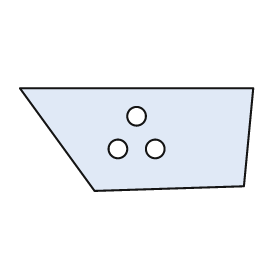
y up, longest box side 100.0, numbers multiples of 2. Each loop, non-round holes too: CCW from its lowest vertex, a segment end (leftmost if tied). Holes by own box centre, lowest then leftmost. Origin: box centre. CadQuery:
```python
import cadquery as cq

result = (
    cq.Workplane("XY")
    .moveTo(-18.0, -22.0)
    .lineTo(46.0, -20.0)
    .lineTo(50.0, 22.0)
    .lineTo(-50.0, 22.0)
    .close()
    .moveTo(-8.0, -4.0)
    .circle(4.0)
    .moveTo(8.0, -4.0)
    .circle(4.0)
    .moveTo(0.0, 10.0)
    .circle(4.0)
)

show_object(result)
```